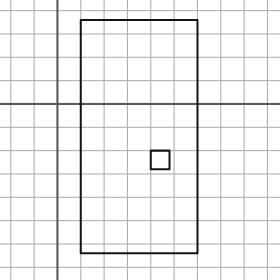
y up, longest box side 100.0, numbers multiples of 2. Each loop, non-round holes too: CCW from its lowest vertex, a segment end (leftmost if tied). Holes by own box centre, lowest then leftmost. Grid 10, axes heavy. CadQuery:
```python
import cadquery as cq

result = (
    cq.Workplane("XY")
    .moveTo(10.0, -64.0)
    .lineTo(60.0, -64.0)
    .lineTo(60.0, 36.0)
    .lineTo(10.0, 36.0)
    .close()
    .moveTo(40.0, -28.0)
    .lineTo(48.0, -28.0)
    .lineTo(48.0, -20.0)
    .lineTo(40.0, -20.0)
    .close()
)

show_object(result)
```